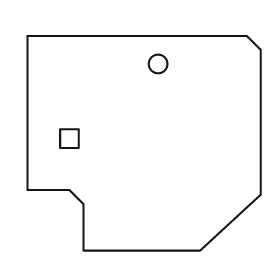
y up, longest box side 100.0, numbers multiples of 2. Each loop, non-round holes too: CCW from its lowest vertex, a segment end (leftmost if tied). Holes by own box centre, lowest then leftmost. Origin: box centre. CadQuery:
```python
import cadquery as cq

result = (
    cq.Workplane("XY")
    .moveTo(-26.0, -46.0)
    .lineTo(24.0, -46.0)
    .lineTo(50.0, -22.0)
    .lineTo(50.0, 40.0)
    .lineTo(44.0, 46.0)
    .lineTo(-50.0, 46.0)
    .lineTo(-50.0, -20.0)
    .lineTo(-32.0, -20.0)
    .lineTo(-26.0, -26.0)
    .close()
    .moveTo(-36.0, -2.0)
    .lineTo(-28.0, -2.0)
    .lineTo(-28.0, 6.0)
    .lineTo(-36.0, 6.0)
    .close()
    .moveTo(6.0, 34.0)
    .circle(4.0)
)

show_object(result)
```